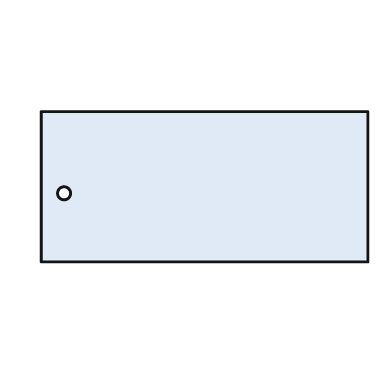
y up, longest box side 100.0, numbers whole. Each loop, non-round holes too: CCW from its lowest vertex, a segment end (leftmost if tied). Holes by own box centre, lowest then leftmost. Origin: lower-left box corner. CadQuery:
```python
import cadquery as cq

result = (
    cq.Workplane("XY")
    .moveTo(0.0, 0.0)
    .lineTo(100.0, 0.0)
    .lineTo(100.0, 46.0)
    .lineTo(0.0, 46.0)
    .close()
    .moveTo(7.0, 21.0)
    .circle(2.0)
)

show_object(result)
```